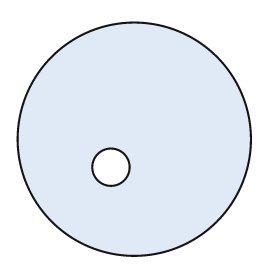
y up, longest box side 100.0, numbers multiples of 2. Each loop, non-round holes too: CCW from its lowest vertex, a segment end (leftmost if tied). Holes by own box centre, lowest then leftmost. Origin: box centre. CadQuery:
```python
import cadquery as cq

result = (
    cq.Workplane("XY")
    .moveTo(0.0, 0.0)
    .circle(50.0)
    .moveTo(-10.0, -12.0)
    .circle(8.0)
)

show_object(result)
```